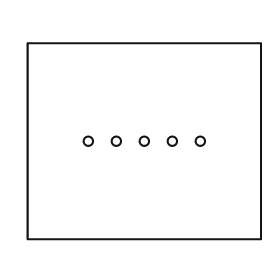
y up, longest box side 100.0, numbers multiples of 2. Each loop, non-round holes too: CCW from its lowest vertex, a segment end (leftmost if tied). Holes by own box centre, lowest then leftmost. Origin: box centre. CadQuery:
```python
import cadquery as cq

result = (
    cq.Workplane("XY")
    .moveTo(-50.0, -42.0)
    .lineTo(50.0, -42.0)
    .lineTo(50.0, 42.0)
    .lineTo(-50.0, 42.0)
    .close()
    .moveTo(-24.0, 0.0)
    .circle(2.0)
    .moveTo(-12.0, 0.0)
    .circle(2.0)
    .moveTo(0.0, 0.0)
    .circle(2.0)
    .moveTo(12.0, 0.0)
    .circle(2.0)
    .moveTo(24.0, 0.0)
    .circle(2.0)
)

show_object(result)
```